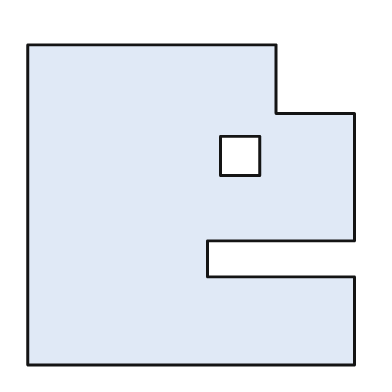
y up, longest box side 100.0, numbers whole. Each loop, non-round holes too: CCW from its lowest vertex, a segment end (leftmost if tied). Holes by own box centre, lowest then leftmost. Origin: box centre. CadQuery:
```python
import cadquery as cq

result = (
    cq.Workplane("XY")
    .moveTo(-50.0, -49.0)
    .lineTo(50.0, -49.0)
    .lineTo(50.0, -22.0)
    .lineTo(5.0, -22.0)
    .lineTo(5.0, -11.0)
    .lineTo(50.0, -11.0)
    .lineTo(50.0, 28.0)
    .lineTo(26.0, 28.0)
    .lineTo(26.0, 49.0)
    .lineTo(-50.0, 49.0)
    .close()
    .moveTo(9.0, 9.0)
    .lineTo(21.0, 9.0)
    .lineTo(21.0, 21.0)
    .lineTo(9.0, 21.0)
    .close()
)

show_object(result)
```